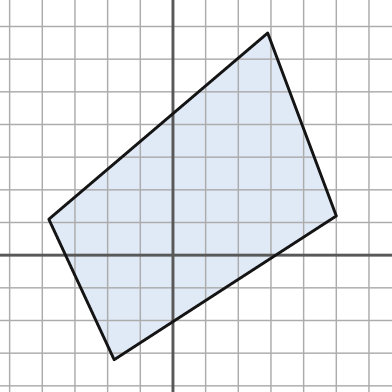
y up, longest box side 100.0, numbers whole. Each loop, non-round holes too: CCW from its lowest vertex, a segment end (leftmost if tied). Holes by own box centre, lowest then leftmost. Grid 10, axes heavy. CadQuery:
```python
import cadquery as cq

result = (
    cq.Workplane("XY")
    .moveTo(-18.0, -32.0)
    .lineTo(50.0, 12.0)
    .lineTo(29.0, 68.0)
    .lineTo(-38.0, 11.0)
    .close()
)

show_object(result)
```